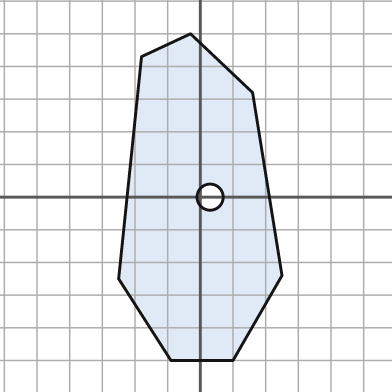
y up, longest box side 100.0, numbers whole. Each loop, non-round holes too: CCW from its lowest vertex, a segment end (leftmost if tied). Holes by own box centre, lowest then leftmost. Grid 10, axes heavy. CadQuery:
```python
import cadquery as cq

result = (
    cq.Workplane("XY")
    .moveTo(-9.0, -50.0)
    .lineTo(10.0, -50.0)
    .lineTo(25.0, -24.0)
    .lineTo(16.0, 32.0)
    .lineTo(-3.0, 50.0)
    .lineTo(-18.0, 43.0)
    .lineTo(-25.0, -25.0)
    .close()
    .moveTo(3.0, 0.0)
    .circle(4.0)
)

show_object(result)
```